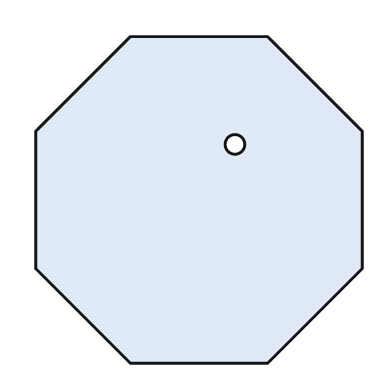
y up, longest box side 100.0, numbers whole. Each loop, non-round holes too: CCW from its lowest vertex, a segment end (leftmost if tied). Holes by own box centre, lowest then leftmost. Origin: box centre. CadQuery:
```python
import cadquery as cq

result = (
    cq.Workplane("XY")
    .moveTo(-21.0, -50.0)
    .lineTo(21.0, -50.0)
    .lineTo(50.0, -21.0)
    .lineTo(50.0, 21.0)
    .lineTo(21.0, 50.0)
    .lineTo(-21.0, 50.0)
    .lineTo(-50.0, 21.0)
    .lineTo(-50.0, -21.0)
    .close()
    .moveTo(11.0, 17.0)
    .circle(3.0)
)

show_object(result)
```